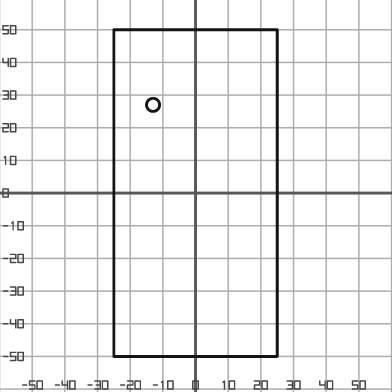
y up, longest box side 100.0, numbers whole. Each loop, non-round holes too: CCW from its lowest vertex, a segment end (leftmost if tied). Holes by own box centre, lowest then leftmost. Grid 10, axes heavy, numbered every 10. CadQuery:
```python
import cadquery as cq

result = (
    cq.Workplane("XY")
    .moveTo(-25.0, -50.0)
    .lineTo(25.0, -50.0)
    .lineTo(25.0, 50.0)
    .lineTo(-25.0, 50.0)
    .close()
    .moveTo(-13.0, 27.0)
    .circle(2.0)
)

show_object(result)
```